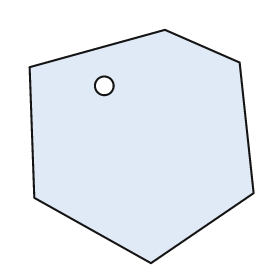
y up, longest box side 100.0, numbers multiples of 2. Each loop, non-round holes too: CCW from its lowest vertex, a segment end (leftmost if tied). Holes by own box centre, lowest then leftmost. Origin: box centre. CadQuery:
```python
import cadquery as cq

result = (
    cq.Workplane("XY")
    .moveTo(4.0, -50.0)
    .lineTo(48.0, -20.0)
    .lineTo(42.0, 36.0)
    .lineTo(10.0, 50.0)
    .lineTo(-48.0, 34.0)
    .lineTo(-46.0, -22.0)
    .close()
    .moveTo(-16.0, 26.0)
    .circle(4.0)
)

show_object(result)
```